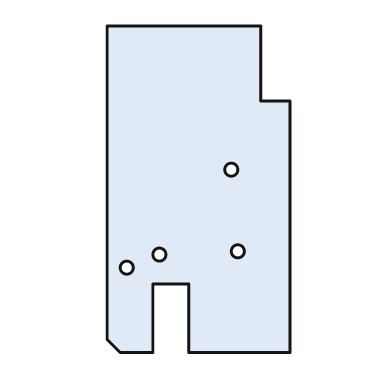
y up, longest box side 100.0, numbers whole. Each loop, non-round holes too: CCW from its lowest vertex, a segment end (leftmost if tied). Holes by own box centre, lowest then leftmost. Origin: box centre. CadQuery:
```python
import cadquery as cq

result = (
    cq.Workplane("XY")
    .moveTo(-24.0, -50.0)
    .lineTo(-14.0, -50.0)
    .lineTo(-14.0, -29.0)
    .lineTo(-3.0, -29.0)
    .lineTo(-3.0, -50.0)
    .lineTo(28.0, -50.0)
    .lineTo(28.0, 27.0)
    .lineTo(19.0, 27.0)
    .lineTo(19.0, 50.0)
    .lineTo(-28.0, 50.0)
    .lineTo(-28.0, -46.0)
    .close()
    .moveTo(-22.0, -24.0)
    .circle(2.0)
    .moveTo(-12.0, -20.0)
    .circle(2.0)
    .moveTo(12.0, -19.0)
    .circle(2.0)
    .moveTo(10.0, 6.0)
    .circle(2.0)
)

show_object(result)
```